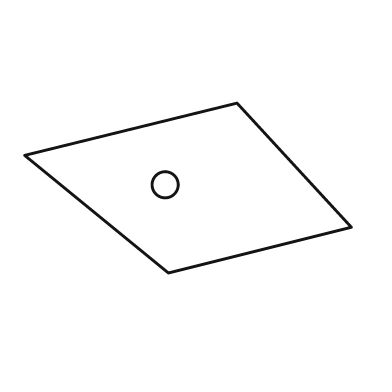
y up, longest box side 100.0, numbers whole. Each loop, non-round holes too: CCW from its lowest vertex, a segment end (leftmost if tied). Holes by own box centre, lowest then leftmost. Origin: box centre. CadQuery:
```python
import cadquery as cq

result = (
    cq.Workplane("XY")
    .moveTo(-6.0, -26.0)
    .lineTo(50.0, -12.0)
    .lineTo(15.0, 26.0)
    .lineTo(-50.0, 10.0)
    .close()
    .moveTo(-7.0, 1.0)
    .circle(4.0)
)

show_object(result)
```